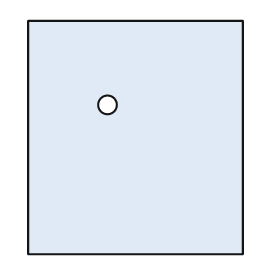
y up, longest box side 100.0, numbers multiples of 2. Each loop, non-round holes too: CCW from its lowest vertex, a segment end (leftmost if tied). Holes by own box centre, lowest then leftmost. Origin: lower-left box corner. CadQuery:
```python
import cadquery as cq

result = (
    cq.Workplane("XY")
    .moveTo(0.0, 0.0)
    .lineTo(92.0, 0.0)
    .lineTo(92.0, 100.0)
    .lineTo(0.0, 100.0)
    .close()
    .moveTo(34.0, 64.0)
    .circle(4.0)
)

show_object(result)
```